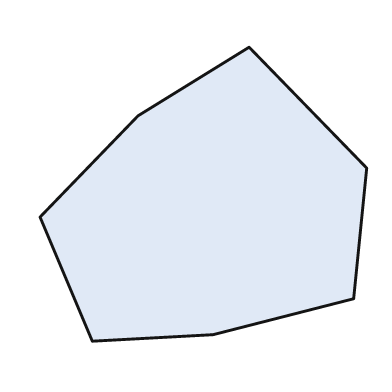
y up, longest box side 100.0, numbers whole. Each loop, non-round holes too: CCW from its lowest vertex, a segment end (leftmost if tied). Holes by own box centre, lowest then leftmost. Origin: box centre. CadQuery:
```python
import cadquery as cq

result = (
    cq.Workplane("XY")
    .moveTo(-34.0, -45.0)
    .lineTo(3.0, -43.0)
    .lineTo(46.0, -32.0)
    .lineTo(50.0, 8.0)
    .lineTo(14.0, 45.0)
    .lineTo(-20.0, 24.0)
    .lineTo(-50.0, -7.0)
    .close()
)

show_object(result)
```